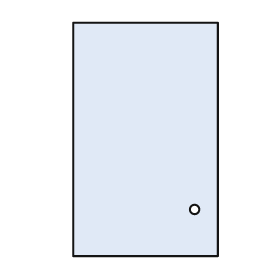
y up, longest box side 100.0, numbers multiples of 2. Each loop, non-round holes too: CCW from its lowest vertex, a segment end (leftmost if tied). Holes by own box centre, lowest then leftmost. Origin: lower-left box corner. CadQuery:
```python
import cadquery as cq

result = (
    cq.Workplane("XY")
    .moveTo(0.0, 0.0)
    .lineTo(62.0, 0.0)
    .lineTo(62.0, 100.0)
    .lineTo(0.0, 100.0)
    .close()
    .moveTo(52.0, 20.0)
    .circle(2.0)
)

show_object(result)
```